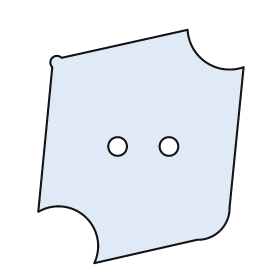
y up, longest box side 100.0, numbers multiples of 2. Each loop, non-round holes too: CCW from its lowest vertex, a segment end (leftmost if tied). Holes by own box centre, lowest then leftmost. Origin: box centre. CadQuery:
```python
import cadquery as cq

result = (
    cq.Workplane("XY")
    .moveTo(-20.0, -50.0)
    .lineTo(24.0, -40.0)
    .threePointArc((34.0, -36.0), (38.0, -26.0))
    .lineTo(44.0, 34.0)
    .threePointArc((28.0, 36.0), (20.0, 50.0))
    .lineTo(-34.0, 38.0)
    .threePointArc((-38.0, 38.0), (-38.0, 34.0))
    .lineTo(-44.0, -28.0)
    .threePointArc((-24.0, -30.0), (-20.0, -50.0))
    .close()
    .moveTo(-10.0, 0.0)
    .circle(4.0)
    .moveTo(12.0, 0.0)
    .circle(4.0)
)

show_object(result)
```